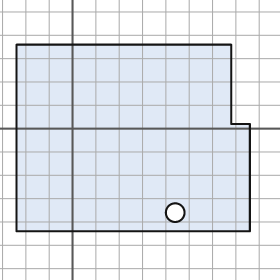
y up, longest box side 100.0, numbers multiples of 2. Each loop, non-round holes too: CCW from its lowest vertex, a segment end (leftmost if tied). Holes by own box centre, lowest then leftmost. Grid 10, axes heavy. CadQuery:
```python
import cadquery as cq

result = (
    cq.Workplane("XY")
    .moveTo(-24.0, -44.0)
    .lineTo(76.0, -44.0)
    .lineTo(76.0, 2.0)
    .lineTo(68.0, 2.0)
    .lineTo(68.0, 36.0)
    .lineTo(-24.0, 36.0)
    .close()
    .moveTo(44.0, -36.0)
    .circle(4.0)
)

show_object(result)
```